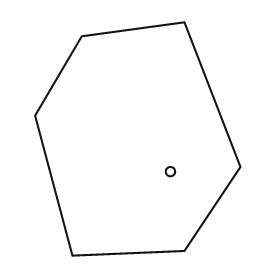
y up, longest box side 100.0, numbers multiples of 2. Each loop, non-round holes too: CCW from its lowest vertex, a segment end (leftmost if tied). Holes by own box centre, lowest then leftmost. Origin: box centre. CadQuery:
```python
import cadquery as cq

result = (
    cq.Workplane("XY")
    .moveTo(-28.0, -50.0)
    .lineTo(20.0, -48.0)
    .lineTo(44.0, -12.0)
    .lineTo(20.0, 50.0)
    .lineTo(-24.0, 44.0)
    .lineTo(-44.0, 10.0)
    .close()
    .moveTo(14.0, -14.0)
    .circle(2.0)
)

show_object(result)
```